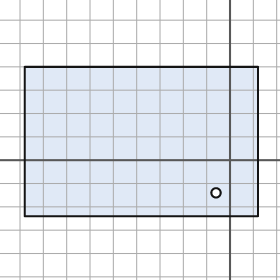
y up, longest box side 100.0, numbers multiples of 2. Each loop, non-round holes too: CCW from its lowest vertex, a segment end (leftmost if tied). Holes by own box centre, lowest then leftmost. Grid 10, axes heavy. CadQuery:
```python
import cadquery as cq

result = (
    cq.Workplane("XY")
    .moveTo(-88.0, -24.0)
    .lineTo(12.0, -24.0)
    .lineTo(12.0, 40.0)
    .lineTo(-88.0, 40.0)
    .close()
    .moveTo(-6.0, -14.0)
    .circle(2.0)
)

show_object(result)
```